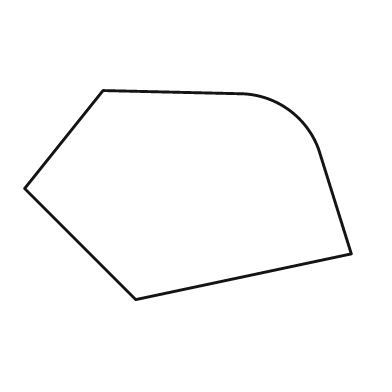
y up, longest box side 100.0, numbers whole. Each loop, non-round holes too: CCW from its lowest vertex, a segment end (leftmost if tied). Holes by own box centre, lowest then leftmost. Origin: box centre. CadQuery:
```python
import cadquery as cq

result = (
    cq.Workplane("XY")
    .moveTo(-16.0, -32.0)
    .lineTo(50.0, -18.0)
    .lineTo(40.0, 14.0)
    .threePointArc((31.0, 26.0), (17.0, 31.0))
    .lineTo(-26.0, 32.0)
    .lineTo(-50.0, 2.0)
    .close()
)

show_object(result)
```